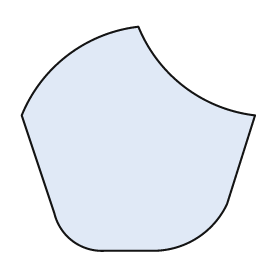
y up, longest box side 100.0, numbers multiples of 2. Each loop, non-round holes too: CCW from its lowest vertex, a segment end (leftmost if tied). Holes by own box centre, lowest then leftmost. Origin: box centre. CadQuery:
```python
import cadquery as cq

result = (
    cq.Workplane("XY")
    .moveTo(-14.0, -48.0)
    .lineTo(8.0, -48.0)
    .threePointArc((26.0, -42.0), (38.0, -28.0))
    .lineTo(50.0, 10.0)
    .threePointArc((20.0, 22.0), (0.0, 48.0))
    .threePointArc((-30.0, 36.0), (-50.0, 10.0))
    .lineTo(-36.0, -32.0)
    .threePointArc((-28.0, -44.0), (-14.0, -48.0))
    .close()
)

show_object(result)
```